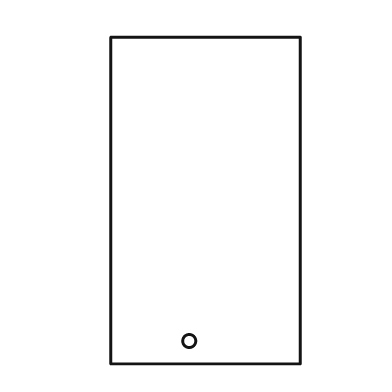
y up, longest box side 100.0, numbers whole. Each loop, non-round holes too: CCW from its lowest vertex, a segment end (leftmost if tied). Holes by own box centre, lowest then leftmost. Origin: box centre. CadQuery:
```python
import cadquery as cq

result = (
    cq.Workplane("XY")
    .moveTo(-29.0, -50.0)
    .lineTo(29.0, -50.0)
    .lineTo(29.0, 50.0)
    .lineTo(-29.0, 50.0)
    .close()
    .moveTo(-5.0, -43.0)
    .circle(2.0)
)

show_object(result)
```